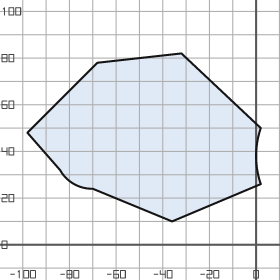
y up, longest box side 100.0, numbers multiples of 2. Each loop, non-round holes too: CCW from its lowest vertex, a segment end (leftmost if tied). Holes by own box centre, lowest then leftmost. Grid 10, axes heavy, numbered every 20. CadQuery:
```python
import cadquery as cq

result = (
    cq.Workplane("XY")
    .moveTo(-36.0, 10.0)
    .lineTo(2.0, 26.0)
    .threePointArc((0.0, 38.0), (2.0, 50.0))
    .lineTo(-32.0, 82.0)
    .lineTo(-68.0, 78.0)
    .lineTo(-98.0, 48.0)
    .lineTo(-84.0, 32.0)
    .threePointArc((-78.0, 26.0), (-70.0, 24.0))
    .close()
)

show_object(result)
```